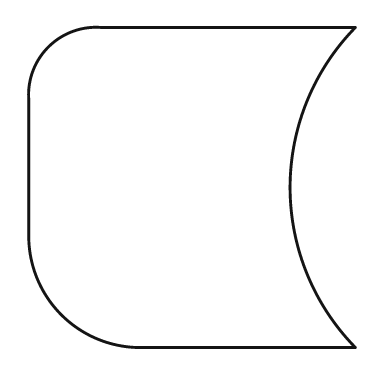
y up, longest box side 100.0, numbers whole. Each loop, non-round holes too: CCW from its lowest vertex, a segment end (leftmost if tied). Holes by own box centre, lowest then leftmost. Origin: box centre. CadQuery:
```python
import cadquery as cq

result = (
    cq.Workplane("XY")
    .moveTo(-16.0, -49.0)
    .lineTo(50.0, -49.0)
    .threePointArc((30.0, 0.0), (50.0, 49.0))
    .lineTo(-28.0, 49.0)
    .threePointArc((-44.0, 43.0), (-50.0, 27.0))
    .lineTo(-50.0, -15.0)
    .threePointArc((-40.0, -39.0), (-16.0, -49.0))
    .close()
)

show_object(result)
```